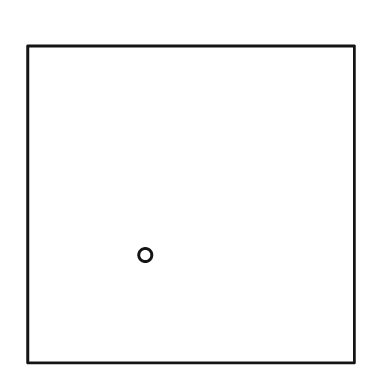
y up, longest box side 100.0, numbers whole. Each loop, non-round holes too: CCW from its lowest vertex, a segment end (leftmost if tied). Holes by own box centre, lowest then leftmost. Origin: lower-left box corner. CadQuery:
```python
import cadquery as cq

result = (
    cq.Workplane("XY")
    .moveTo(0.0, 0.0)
    .lineTo(100.0, 0.0)
    .lineTo(100.0, 97.0)
    .lineTo(0.0, 97.0)
    .close()
    .moveTo(36.0, 33.0)
    .circle(2.0)
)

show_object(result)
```